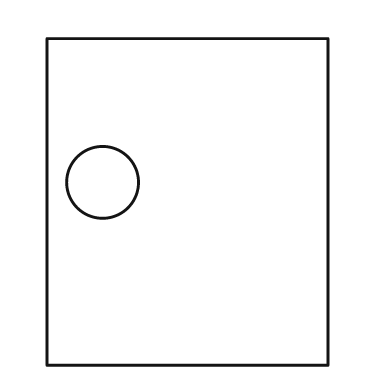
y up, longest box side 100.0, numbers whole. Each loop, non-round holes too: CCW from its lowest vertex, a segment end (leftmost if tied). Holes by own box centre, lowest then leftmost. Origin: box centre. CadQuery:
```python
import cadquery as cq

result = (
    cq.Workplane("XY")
    .moveTo(-43.0, -50.0)
    .lineTo(43.0, -50.0)
    .lineTo(43.0, 50.0)
    .lineTo(-43.0, 50.0)
    .close()
    .moveTo(-26.0, 6.0)
    .circle(11.0)
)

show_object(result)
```